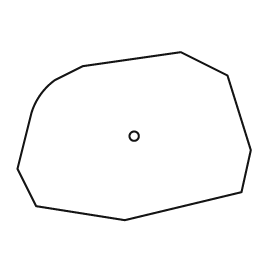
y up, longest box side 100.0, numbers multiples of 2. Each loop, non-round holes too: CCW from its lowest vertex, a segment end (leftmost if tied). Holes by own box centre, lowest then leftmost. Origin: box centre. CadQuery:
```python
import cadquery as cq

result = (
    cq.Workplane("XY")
    .moveTo(-4.0, -36.0)
    .lineTo(46.0, -24.0)
    .lineTo(50.0, -6.0)
    .lineTo(40.0, 26.0)
    .lineTo(20.0, 36.0)
    .lineTo(-22.0, 30.0)
    .lineTo(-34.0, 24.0)
    .threePointArc((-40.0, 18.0), (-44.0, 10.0))
    .lineTo(-50.0, -14.0)
    .lineTo(-42.0, -30.0)
    .close()
    .moveTo(0.0, 0.0)
    .circle(2.0)
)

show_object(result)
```